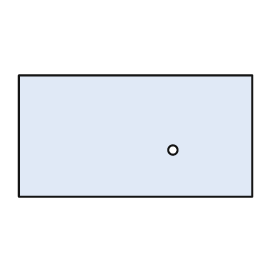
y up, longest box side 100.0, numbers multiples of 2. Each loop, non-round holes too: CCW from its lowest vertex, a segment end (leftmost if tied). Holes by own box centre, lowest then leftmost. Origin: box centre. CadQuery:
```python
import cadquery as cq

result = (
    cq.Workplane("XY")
    .moveTo(-50.0, -26.0)
    .lineTo(50.0, -26.0)
    .lineTo(50.0, 26.0)
    .lineTo(-50.0, 26.0)
    .close()
    .moveTo(16.0, -6.0)
    .circle(2.0)
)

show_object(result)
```